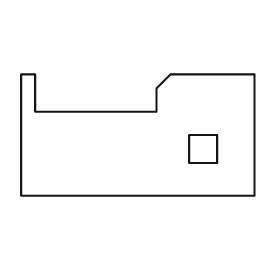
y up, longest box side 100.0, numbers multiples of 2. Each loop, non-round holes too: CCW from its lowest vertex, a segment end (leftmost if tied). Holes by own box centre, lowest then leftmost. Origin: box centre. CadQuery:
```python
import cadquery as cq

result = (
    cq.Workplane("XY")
    .moveTo(-50.0, -26.0)
    .lineTo(50.0, -26.0)
    .lineTo(50.0, 26.0)
    .lineTo(14.0, 26.0)
    .lineTo(8.0, 20.0)
    .lineTo(8.0, 10.0)
    .lineTo(-44.0, 10.0)
    .lineTo(-44.0, 26.0)
    .lineTo(-50.0, 26.0)
    .close()
    .moveTo(22.0, -12.0)
    .lineTo(34.0, -12.0)
    .lineTo(34.0, 0.0)
    .lineTo(22.0, 0.0)
    .close()
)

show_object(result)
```